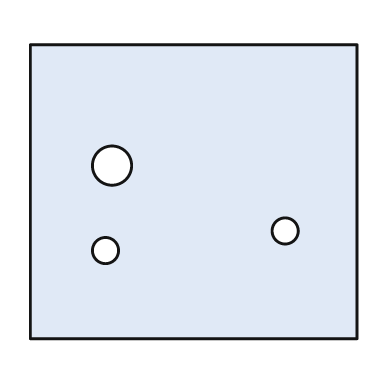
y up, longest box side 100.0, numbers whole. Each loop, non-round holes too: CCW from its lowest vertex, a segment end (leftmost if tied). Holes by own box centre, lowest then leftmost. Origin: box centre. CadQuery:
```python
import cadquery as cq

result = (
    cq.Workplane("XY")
    .moveTo(-50.0, -45.0)
    .lineTo(50.0, -45.0)
    .lineTo(50.0, 45.0)
    .lineTo(-50.0, 45.0)
    .close()
    .moveTo(-27.0, -18.0)
    .circle(4.0)
    .moveTo(28.0, -12.0)
    .circle(4.0)
    .moveTo(-25.0, 8.0)
    .circle(6.0)
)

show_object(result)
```